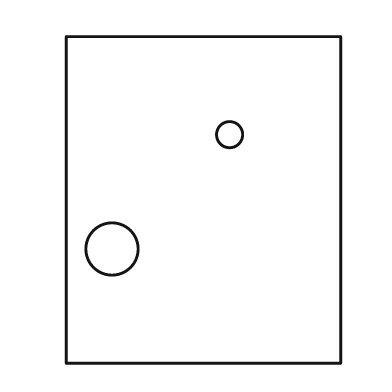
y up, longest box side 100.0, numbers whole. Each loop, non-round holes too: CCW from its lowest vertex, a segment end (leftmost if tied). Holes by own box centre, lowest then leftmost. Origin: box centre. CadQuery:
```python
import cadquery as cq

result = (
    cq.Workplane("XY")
    .moveTo(-42.0, -50.0)
    .lineTo(42.0, -50.0)
    .lineTo(42.0, 50.0)
    .lineTo(-42.0, 50.0)
    .close()
    .moveTo(-28.0, -15.0)
    .circle(8.0)
    .moveTo(8.0, 20.0)
    .circle(4.0)
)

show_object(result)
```